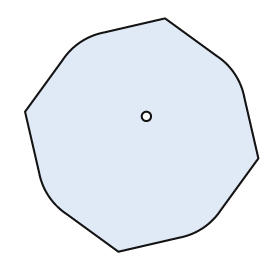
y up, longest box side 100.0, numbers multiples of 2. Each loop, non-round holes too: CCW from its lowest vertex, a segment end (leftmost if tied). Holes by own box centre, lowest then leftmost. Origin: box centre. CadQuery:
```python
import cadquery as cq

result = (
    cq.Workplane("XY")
    .moveTo(-10.0, -50.0)
    .lineTo(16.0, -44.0)
    .threePointArc((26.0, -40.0), (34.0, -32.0))
    .lineTo(50.0, -10.0)
    .lineTo(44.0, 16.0)
    .threePointArc((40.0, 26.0), (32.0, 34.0))
    .lineTo(10.0, 50.0)
    .lineTo(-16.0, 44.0)
    .threePointArc((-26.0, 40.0), (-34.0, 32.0))
    .lineTo(-50.0, 10.0)
    .lineTo(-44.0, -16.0)
    .threePointArc((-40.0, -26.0), (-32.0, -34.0))
    .close()
    .moveTo(2.0, 8.0)
    .circle(2.0)
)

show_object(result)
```